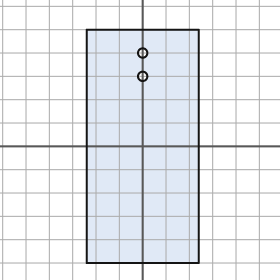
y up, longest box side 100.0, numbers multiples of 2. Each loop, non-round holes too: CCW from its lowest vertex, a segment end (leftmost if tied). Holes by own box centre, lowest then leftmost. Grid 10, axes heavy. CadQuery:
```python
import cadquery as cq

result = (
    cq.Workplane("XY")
    .moveTo(-24.0, -50.0)
    .lineTo(24.0, -50.0)
    .lineTo(24.0, 50.0)
    .lineTo(-24.0, 50.0)
    .close()
    .moveTo(0.0, 30.0)
    .circle(2.0)
    .moveTo(0.0, 40.0)
    .circle(2.0)
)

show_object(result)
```